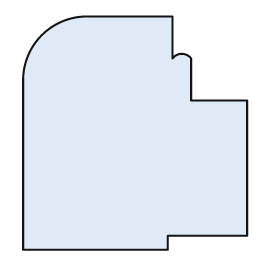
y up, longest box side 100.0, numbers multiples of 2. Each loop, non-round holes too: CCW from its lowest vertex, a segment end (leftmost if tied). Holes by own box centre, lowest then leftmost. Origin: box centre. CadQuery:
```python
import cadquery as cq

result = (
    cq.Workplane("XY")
    .moveTo(-48.0, -50.0)
    .lineTo(14.0, -50.0)
    .lineTo(14.0, -44.0)
    .lineTo(48.0, -44.0)
    .lineTo(48.0, 14.0)
    .lineTo(24.0, 14.0)
    .lineTo(24.0, 32.0)
    .threePointArc((20.0, 34.0), (16.0, 32.0))
    .lineTo(16.0, 50.0)
    .lineTo(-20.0, 50.0)
    .threePointArc((-40.0, 42.0), (-48.0, 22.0))
    .close()
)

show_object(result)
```